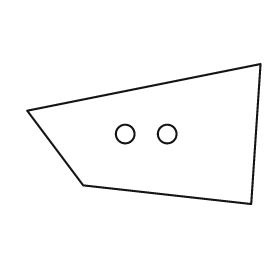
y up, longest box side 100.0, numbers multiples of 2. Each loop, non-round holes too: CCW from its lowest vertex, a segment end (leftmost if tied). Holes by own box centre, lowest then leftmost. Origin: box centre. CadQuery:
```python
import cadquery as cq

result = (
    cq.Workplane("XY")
    .moveTo(46.0, -30.0)
    .lineTo(50.0, 30.0)
    .lineTo(-50.0, 10.0)
    .lineTo(-26.0, -22.0)
    .close()
    .moveTo(-8.0, 0.0)
    .circle(4.0)
    .moveTo(10.0, 0.0)
    .circle(4.0)
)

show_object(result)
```